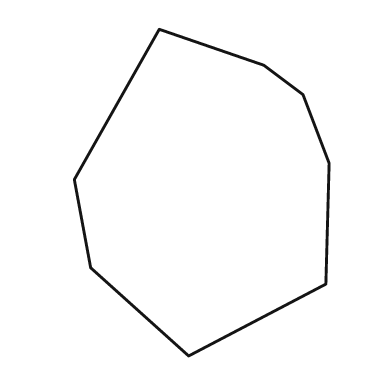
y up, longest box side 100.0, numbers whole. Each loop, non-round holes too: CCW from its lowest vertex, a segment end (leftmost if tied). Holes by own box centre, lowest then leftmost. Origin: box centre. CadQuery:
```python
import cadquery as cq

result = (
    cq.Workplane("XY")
    .moveTo(-4.0, -50.0)
    .lineTo(38.0, -28.0)
    .lineTo(39.0, 9.0)
    .lineTo(31.0, 30.0)
    .lineTo(19.0, 39.0)
    .lineTo(-13.0, 50.0)
    .lineTo(-39.0, 4.0)
    .lineTo(-34.0, -23.0)
    .close()
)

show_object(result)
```